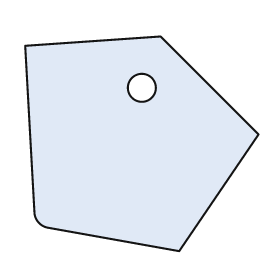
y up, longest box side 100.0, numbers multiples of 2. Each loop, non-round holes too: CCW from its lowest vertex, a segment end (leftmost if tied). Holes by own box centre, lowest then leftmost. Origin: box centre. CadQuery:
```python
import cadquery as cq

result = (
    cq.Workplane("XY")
    .moveTo(16.0, -46.0)
    .lineTo(50.0, 4.0)
    .lineTo(8.0, 46.0)
    .lineTo(-50.0, 42.0)
    .lineTo(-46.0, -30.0)
    .threePointArc((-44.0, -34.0), (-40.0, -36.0))
    .close()
    .moveTo(0.0, 24.0)
    .circle(6.0)
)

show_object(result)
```